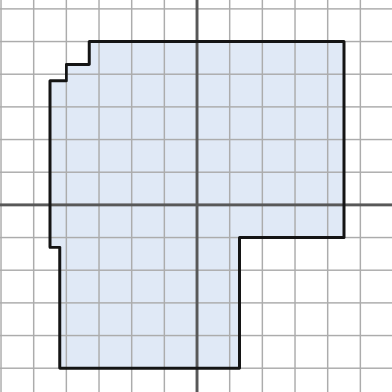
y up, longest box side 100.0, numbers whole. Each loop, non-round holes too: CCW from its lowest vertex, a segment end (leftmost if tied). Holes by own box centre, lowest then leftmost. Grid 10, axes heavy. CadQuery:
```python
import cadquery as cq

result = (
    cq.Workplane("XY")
    .moveTo(-42.0, -50.0)
    .lineTo(13.0, -50.0)
    .lineTo(13.0, -10.0)
    .lineTo(45.0, -10.0)
    .lineTo(45.0, 50.0)
    .lineTo(-33.0, 50.0)
    .lineTo(-33.0, 43.0)
    .lineTo(-40.0, 43.0)
    .lineTo(-40.0, 38.0)
    .lineTo(-45.0, 38.0)
    .lineTo(-45.0, -13.0)
    .lineTo(-42.0, -13.0)
    .close()
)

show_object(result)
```